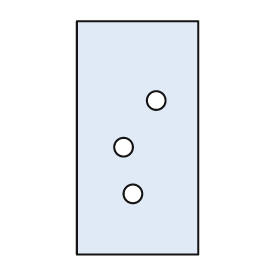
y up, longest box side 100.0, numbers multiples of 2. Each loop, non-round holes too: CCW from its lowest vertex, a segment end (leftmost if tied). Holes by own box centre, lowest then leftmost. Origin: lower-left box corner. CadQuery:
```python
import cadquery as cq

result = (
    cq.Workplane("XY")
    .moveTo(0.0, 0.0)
    .lineTo(52.0, 0.0)
    .lineTo(52.0, 100.0)
    .lineTo(0.0, 100.0)
    .close()
    .moveTo(24.0, 26.0)
    .circle(4.0)
    .moveTo(20.0, 46.0)
    .circle(4.0)
    .moveTo(34.0, 66.0)
    .circle(4.0)
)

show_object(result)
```